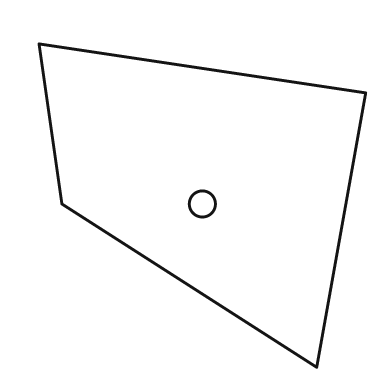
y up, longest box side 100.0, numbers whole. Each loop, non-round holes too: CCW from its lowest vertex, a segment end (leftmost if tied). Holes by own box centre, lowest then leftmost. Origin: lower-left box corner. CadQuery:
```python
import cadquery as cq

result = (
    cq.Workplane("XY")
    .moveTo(85.0, 0.0)
    .lineTo(100.0, 84.0)
    .lineTo(0.0, 99.0)
    .lineTo(7.0, 50.0)
    .close()
    .moveTo(50.0, 50.0)
    .circle(4.0)
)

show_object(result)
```